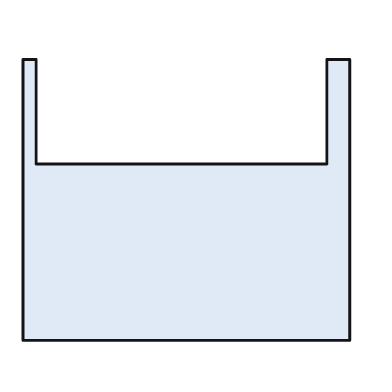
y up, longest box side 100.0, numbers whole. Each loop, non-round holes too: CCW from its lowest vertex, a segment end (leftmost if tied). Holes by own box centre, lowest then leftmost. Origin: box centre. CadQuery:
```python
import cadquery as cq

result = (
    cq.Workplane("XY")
    .moveTo(-50.0, -43.0)
    .lineTo(50.0, -43.0)
    .lineTo(50.0, 43.0)
    .lineTo(43.0, 43.0)
    .lineTo(43.0, 11.0)
    .lineTo(-46.0, 11.0)
    .lineTo(-46.0, 43.0)
    .lineTo(-50.0, 43.0)
    .close()
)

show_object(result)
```